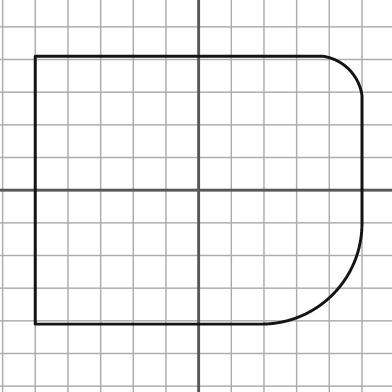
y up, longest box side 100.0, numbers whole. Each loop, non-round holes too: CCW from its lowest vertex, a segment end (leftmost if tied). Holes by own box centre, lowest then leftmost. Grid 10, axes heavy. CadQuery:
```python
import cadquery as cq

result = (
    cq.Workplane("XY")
    .moveTo(-50.0, -41.0)
    .lineTo(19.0, -41.0)
    .threePointArc((41.0, -32.0), (50.0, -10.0))
    .lineTo(50.0, 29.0)
    .threePointArc((46.0, 37.0), (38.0, 41.0))
    .lineTo(-50.0, 41.0)
    .close()
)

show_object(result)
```